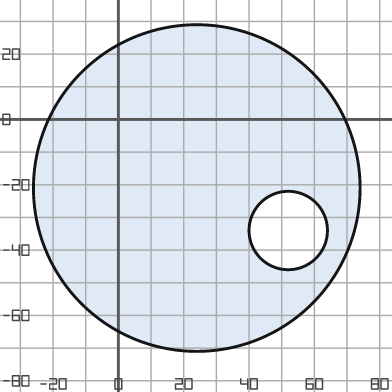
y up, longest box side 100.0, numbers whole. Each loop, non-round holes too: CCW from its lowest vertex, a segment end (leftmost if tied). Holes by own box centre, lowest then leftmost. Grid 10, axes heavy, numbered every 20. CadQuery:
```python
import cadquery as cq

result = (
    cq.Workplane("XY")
    .moveTo(24.0, -21.0)
    .circle(50.0)
    .moveTo(52.0, -34.0)
    .circle(12.0)
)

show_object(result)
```